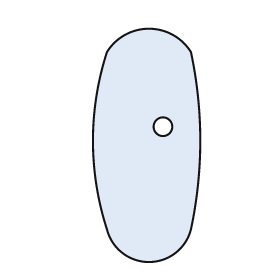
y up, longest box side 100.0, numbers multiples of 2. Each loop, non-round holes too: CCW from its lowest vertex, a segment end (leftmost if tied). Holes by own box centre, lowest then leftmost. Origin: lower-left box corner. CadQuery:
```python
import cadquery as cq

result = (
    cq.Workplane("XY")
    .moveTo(6.0, 14.0)
    .threePointArc((24.0, 0.0), (42.0, 14.0))
    .threePointArc((46.0, 52.0), (42.0, 90.0))
    .threePointArc((24.0, 100.0), (6.0, 90.0))
    .threePointArc((0.0, 52.0), (6.0, 14.0))
    .close()
    .moveTo(30.0, 58.0)
    .circle(4.0)
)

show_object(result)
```